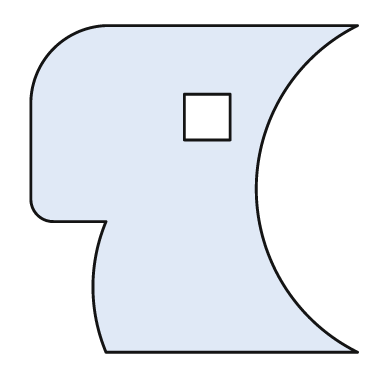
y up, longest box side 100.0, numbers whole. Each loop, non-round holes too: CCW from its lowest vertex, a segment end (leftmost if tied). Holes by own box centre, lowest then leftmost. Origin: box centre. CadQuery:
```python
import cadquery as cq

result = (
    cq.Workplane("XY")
    .moveTo(-27.0, -50.0)
    .lineTo(50.0, -50.0)
    .threePointArc((19.0, 0.0), (50.0, 50.0))
    .lineTo(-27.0, 50.0)
    .threePointArc((-43.0, 43.0), (-50.0, 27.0))
    .lineTo(-50.0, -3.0)
    .threePointArc((-48.0, -8.0), (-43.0, -10.0))
    .lineTo(-27.0, -10.0)
    .threePointArc((-31.0, -30.0), (-27.0, -50.0))
    .close()
    .moveTo(-3.0, 15.0)
    .lineTo(11.0, 15.0)
    .lineTo(11.0, 29.0)
    .lineTo(-3.0, 29.0)
    .close()
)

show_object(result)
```